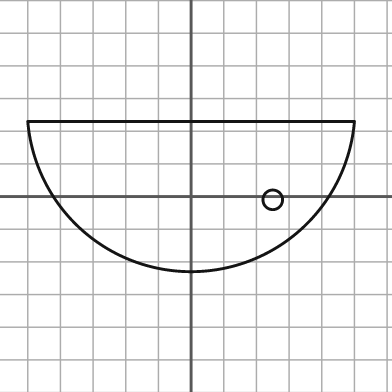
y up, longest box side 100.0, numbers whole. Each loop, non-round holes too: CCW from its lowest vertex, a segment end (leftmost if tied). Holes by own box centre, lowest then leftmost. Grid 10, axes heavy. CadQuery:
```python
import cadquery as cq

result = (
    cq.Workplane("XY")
    .moveTo(-50.0, 23.0)
    .threePointArc((0.0, -23.0), (50.0, 23.0))
    .close()
    .moveTo(25.0, -1.0)
    .circle(3.0)
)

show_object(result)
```